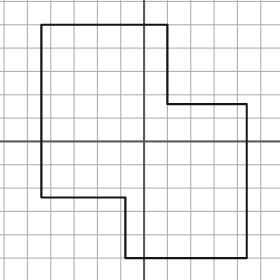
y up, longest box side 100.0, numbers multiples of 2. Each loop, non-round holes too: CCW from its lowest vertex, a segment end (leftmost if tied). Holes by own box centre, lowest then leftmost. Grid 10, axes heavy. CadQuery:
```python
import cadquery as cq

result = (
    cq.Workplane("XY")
    .moveTo(-8.0, -50.0)
    .lineTo(44.0, -50.0)
    .lineTo(44.0, 16.0)
    .lineTo(10.0, 16.0)
    .lineTo(10.0, 50.0)
    .lineTo(-44.0, 50.0)
    .lineTo(-44.0, -24.0)
    .lineTo(-8.0, -24.0)
    .close()
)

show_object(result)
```